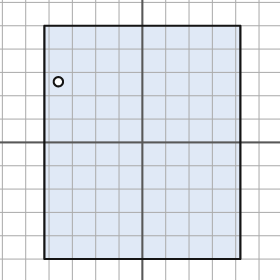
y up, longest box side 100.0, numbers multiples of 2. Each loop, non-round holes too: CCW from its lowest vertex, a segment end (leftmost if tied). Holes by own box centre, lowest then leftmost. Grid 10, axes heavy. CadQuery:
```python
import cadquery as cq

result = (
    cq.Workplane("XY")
    .moveTo(-42.0, -50.0)
    .lineTo(42.0, -50.0)
    .lineTo(42.0, 50.0)
    .lineTo(-42.0, 50.0)
    .close()
    .moveTo(-36.0, 26.0)
    .circle(2.0)
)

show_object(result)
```